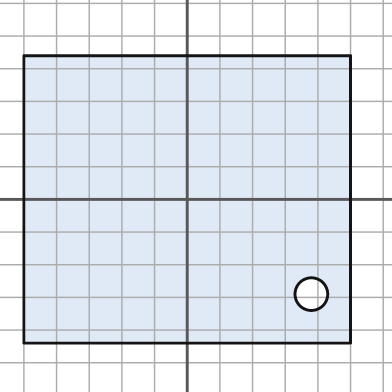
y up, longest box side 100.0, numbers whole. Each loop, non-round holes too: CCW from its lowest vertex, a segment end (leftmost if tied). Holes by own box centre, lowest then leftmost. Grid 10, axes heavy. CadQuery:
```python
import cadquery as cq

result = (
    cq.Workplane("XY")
    .moveTo(-50.0, -44.0)
    .lineTo(50.0, -44.0)
    .lineTo(50.0, 44.0)
    .lineTo(-50.0, 44.0)
    .close()
    .moveTo(38.0, -29.0)
    .circle(5.0)
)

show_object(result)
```